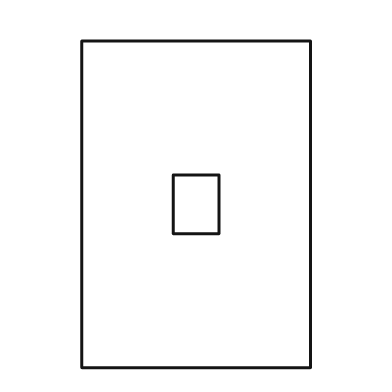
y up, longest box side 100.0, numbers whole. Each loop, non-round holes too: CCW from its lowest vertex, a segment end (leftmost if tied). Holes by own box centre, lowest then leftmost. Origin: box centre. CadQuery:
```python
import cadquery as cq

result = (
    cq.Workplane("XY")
    .moveTo(-35.0, -50.0)
    .lineTo(35.0, -50.0)
    .lineTo(35.0, 50.0)
    .lineTo(-35.0, 50.0)
    .close()
    .moveTo(-7.0, -9.0)
    .lineTo(7.0, -9.0)
    .lineTo(7.0, 9.0)
    .lineTo(-7.0, 9.0)
    .close()
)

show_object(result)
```